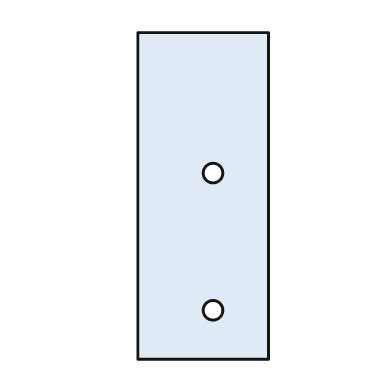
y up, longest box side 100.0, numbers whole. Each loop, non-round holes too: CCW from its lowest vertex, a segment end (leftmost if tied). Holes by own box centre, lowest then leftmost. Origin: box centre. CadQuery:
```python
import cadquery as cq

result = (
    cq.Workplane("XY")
    .moveTo(-20.0, -50.0)
    .lineTo(20.0, -50.0)
    .lineTo(20.0, 50.0)
    .lineTo(-20.0, 50.0)
    .close()
    .moveTo(3.0, -35.0)
    .circle(3.0)
    .moveTo(3.0, 7.0)
    .circle(3.0)
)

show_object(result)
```